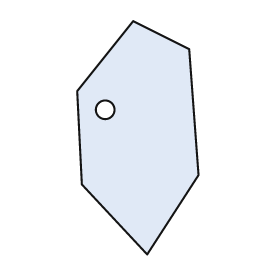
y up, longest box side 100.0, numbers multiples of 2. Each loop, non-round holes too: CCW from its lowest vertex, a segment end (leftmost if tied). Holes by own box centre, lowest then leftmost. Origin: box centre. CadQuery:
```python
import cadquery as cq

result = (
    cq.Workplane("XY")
    .moveTo(4.0, -50.0)
    .lineTo(26.0, -16.0)
    .lineTo(22.0, 38.0)
    .lineTo(-2.0, 50.0)
    .lineTo(-26.0, 20.0)
    .lineTo(-24.0, -20.0)
    .close()
    .moveTo(-14.0, 12.0)
    .circle(4.0)
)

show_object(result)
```